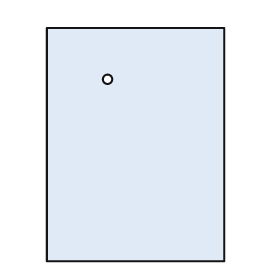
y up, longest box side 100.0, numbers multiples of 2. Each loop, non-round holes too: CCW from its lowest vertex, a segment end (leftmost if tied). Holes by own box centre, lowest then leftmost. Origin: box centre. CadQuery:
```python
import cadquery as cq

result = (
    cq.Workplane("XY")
    .moveTo(-38.0, -50.0)
    .lineTo(38.0, -50.0)
    .lineTo(38.0, 50.0)
    .lineTo(-38.0, 50.0)
    .close()
    .moveTo(-12.0, 28.0)
    .circle(2.0)
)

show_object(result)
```